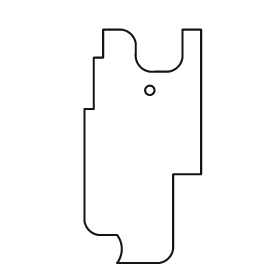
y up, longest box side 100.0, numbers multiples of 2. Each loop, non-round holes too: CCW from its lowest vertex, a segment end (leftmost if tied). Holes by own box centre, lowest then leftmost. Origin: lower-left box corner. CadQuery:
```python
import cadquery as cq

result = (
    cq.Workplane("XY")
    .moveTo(14.0, 0.0)
    .lineTo(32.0, 0.0)
    .threePointArc((36.0, 2.0), (38.0, 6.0))
    .lineTo(38.0, 38.0)
    .lineTo(50.0, 38.0)
    .lineTo(50.0, 100.0)
    .lineTo(42.0, 100.0)
    .lineTo(42.0, 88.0)
    .threePointArc((40.0, 84.0), (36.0, 82.0))
    .lineTo(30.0, 82.0)
    .threePointArc((24.0, 84.0), (22.0, 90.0))
    .lineTo(22.0, 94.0)
    .threePointArc((20.0, 98.0), (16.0, 100.0))
    .lineTo(8.0, 100.0)
    .lineTo(8.0, 88.0)
    .lineTo(4.0, 88.0)
    .lineTo(4.0, 66.0)
    .lineTo(0.0, 66.0)
    .lineTo(0.0, 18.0)
    .threePointArc((2.0, 14.0), (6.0, 12.0))
    .lineTo(14.0, 12.0)
    .threePointArc((16.0, 6.0), (14.0, 0.0))
    .close()
    .moveTo(28.0, 74.0)
    .circle(2.0)
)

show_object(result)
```